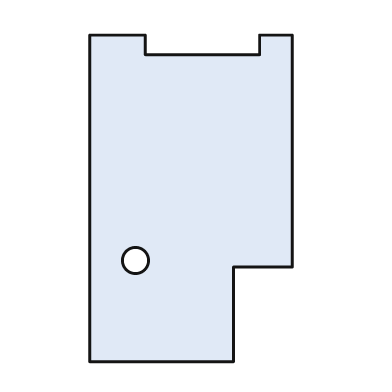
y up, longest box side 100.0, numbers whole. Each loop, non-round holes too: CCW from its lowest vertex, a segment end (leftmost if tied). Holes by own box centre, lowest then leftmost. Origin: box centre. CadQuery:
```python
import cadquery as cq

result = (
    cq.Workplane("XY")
    .moveTo(-31.0, -50.0)
    .lineTo(13.0, -50.0)
    .lineTo(13.0, -21.0)
    .lineTo(31.0, -21.0)
    .lineTo(31.0, 50.0)
    .lineTo(21.0, 50.0)
    .lineTo(21.0, 44.0)
    .lineTo(-14.0, 44.0)
    .lineTo(-14.0, 50.0)
    .lineTo(-31.0, 50.0)
    .close()
    .moveTo(-17.0, -19.0)
    .circle(4.0)
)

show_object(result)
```